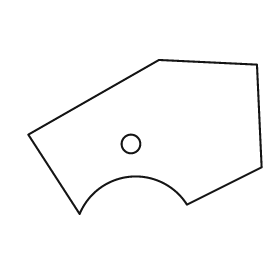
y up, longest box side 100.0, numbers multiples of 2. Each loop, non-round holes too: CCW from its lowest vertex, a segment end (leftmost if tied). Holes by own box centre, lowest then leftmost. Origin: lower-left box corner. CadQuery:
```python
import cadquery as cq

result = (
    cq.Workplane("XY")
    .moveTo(22.0, 0.0)
    .threePointArc((44.0, 16.0), (68.0, 4.0))
    .lineTo(100.0, 20.0)
    .lineTo(98.0, 64.0)
    .lineTo(56.0, 66.0)
    .lineTo(0.0, 34.0)
    .close()
    .moveTo(44.0, 30.0)
    .circle(4.0)
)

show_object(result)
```